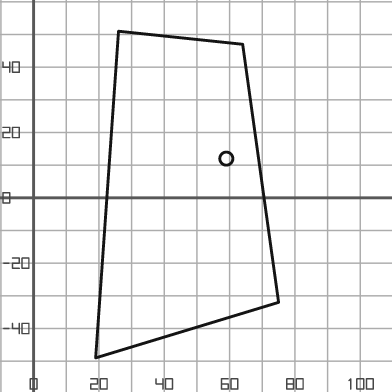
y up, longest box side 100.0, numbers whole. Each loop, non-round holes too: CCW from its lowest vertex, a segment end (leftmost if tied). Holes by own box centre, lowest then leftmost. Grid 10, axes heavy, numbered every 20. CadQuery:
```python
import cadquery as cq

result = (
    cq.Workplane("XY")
    .moveTo(19.0, -49.0)
    .lineTo(75.0, -32.0)
    .lineTo(64.0, 47.0)
    .lineTo(26.0, 51.0)
    .close()
    .moveTo(59.0, 12.0)
    .circle(2.0)
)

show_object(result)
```